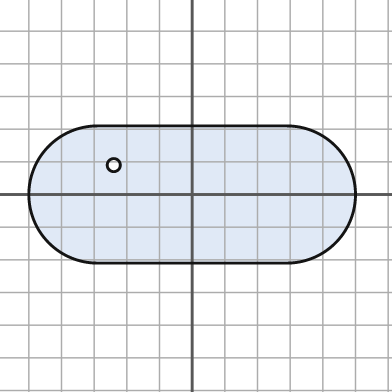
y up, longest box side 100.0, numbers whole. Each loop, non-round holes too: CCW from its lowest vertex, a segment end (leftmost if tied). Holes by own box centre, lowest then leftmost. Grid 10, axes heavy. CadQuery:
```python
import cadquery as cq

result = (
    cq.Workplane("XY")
    .moveTo(-29.0, -21.0)
    .lineTo(29.0, -21.0)
    .threePointArc((50.0, 0.0), (29.0, 21.0))
    .lineTo(-29.0, 21.0)
    .threePointArc((-50.0, 0.0), (-29.0, -21.0))
    .close()
    .moveTo(-24.0, 9.0)
    .circle(2.0)
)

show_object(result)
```